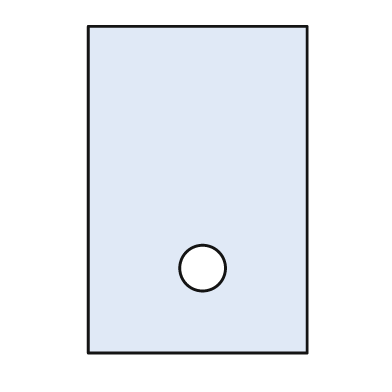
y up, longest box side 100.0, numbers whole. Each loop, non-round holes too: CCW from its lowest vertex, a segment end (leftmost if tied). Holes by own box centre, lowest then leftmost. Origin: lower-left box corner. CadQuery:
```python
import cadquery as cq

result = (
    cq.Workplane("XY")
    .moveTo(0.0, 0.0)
    .lineTo(67.0, 0.0)
    .lineTo(67.0, 100.0)
    .lineTo(0.0, 100.0)
    .close()
    .moveTo(35.0, 26.0)
    .circle(7.0)
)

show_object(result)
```